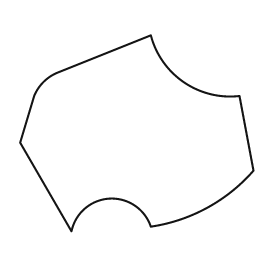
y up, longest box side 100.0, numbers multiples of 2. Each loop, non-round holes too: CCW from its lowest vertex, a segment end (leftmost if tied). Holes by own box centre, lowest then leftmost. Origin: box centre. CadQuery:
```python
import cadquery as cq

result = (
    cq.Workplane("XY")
    .moveTo(-28.0, -42.0)
    .threePointArc((-12.0, -28.0), (6.0, -40.0))
    .threePointArc((30.0, -32.0), (50.0, -16.0))
    .lineTo(44.0, 16.0)
    .threePointArc((20.0, 22.0), (6.0, 42.0))
    .lineTo(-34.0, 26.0)
    .threePointArc((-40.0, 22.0), (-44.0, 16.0))
    .lineTo(-50.0, -4.0)
    .close()
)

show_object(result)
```